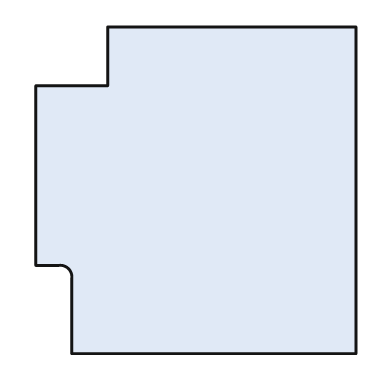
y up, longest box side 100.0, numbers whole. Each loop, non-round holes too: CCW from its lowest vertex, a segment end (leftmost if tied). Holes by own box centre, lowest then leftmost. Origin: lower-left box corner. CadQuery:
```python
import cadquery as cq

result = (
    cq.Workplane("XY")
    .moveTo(11.0, 0.0)
    .lineTo(98.0, 0.0)
    .lineTo(98.0, 100.0)
    .lineTo(22.0, 100.0)
    .lineTo(22.0, 82.0)
    .lineTo(0.0, 82.0)
    .lineTo(0.0, 27.0)
    .lineTo(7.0, 27.0)
    .threePointArc((10.0, 26.0), (11.0, 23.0))
    .close()
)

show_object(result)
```